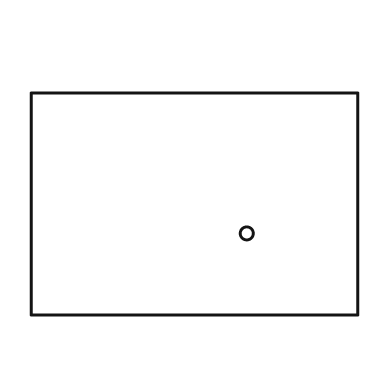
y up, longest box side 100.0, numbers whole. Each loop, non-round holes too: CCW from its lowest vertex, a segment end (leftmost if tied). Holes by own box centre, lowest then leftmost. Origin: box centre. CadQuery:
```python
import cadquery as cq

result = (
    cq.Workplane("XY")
    .moveTo(-50.0, -34.0)
    .lineTo(50.0, -34.0)
    .lineTo(50.0, 34.0)
    .lineTo(-50.0, 34.0)
    .close()
    .moveTo(16.0, -9.0)
    .circle(2.0)
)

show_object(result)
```